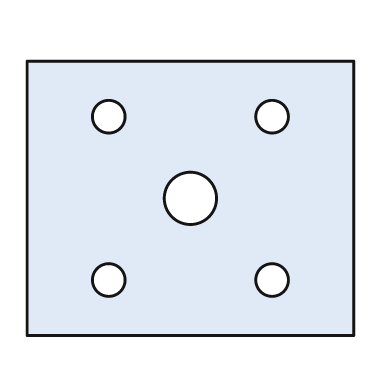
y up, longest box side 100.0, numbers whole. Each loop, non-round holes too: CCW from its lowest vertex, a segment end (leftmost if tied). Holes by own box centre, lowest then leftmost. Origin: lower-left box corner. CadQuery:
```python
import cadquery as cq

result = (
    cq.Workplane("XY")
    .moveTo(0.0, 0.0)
    .lineTo(100.0, 0.0)
    .lineTo(100.0, 84.0)
    .lineTo(0.0, 84.0)
    .close()
    .moveTo(25.0, 17.0)
    .circle(5.0)
    .moveTo(75.0, 17.0)
    .circle(5.0)
    .moveTo(50.0, 42.0)
    .circle(8.0)
    .moveTo(25.0, 67.0)
    .circle(5.0)
    .moveTo(75.0, 67.0)
    .circle(5.0)
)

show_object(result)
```